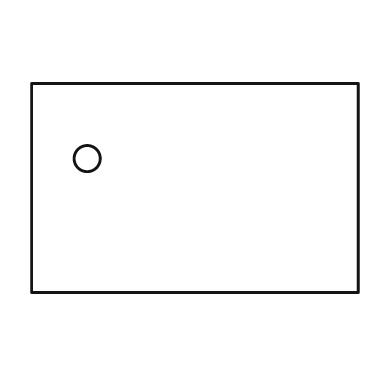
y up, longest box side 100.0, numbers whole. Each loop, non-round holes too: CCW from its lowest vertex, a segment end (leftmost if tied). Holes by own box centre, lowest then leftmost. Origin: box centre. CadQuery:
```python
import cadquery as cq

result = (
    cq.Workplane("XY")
    .moveTo(-50.0, -32.0)
    .lineTo(50.0, -32.0)
    .lineTo(50.0, 32.0)
    .lineTo(-50.0, 32.0)
    .close()
    .moveTo(-33.0, 9.0)
    .circle(4.0)
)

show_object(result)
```